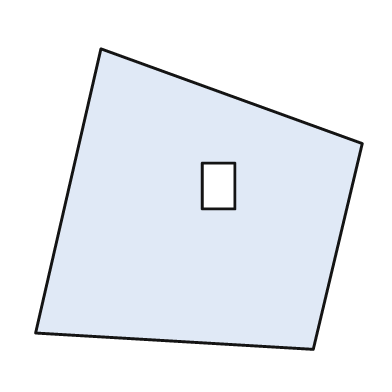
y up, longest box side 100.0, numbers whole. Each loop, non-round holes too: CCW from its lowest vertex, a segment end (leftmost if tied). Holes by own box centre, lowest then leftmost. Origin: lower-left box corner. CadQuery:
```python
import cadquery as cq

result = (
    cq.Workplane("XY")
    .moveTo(85.0, 0.0)
    .lineTo(100.0, 63.0)
    .lineTo(20.0, 92.0)
    .lineTo(0.0, 5.0)
    .close()
    .moveTo(51.0, 43.0)
    .lineTo(61.0, 43.0)
    .lineTo(61.0, 57.0)
    .lineTo(51.0, 57.0)
    .close()
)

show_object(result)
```